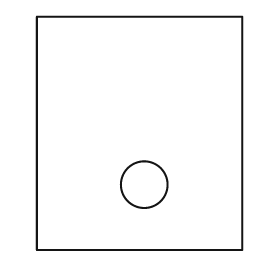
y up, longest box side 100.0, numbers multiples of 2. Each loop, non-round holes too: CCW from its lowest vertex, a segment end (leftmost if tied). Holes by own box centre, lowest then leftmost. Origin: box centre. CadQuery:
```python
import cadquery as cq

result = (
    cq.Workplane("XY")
    .moveTo(-44.0, -50.0)
    .lineTo(44.0, -50.0)
    .lineTo(44.0, 50.0)
    .lineTo(-44.0, 50.0)
    .close()
    .moveTo(2.0, -22.0)
    .circle(10.0)
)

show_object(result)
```